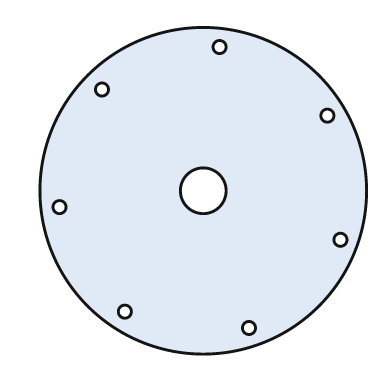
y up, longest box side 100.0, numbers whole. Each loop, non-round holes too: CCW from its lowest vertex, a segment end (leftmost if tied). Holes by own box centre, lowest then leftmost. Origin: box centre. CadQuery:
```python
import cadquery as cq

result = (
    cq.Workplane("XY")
    .moveTo(0.0, 0.0)
    .circle(50.0)
    .moveTo(14.0, -42.0)
    .circle(2.0)
    .moveTo(-24.0, -37.0)
    .circle(2.0)
    .moveTo(42.0, -15.0)
    .circle(2.0)
    .moveTo(-44.0, -5.0)
    .circle(2.0)
    .moveTo(0.0, 0.0)
    .circle(7.0)
    .moveTo(38.0, 23.0)
    .circle(2.0)
    .moveTo(-31.0, 31.0)
    .circle(2.0)
    .moveTo(5.0, 44.0)
    .circle(2.0)
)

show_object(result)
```